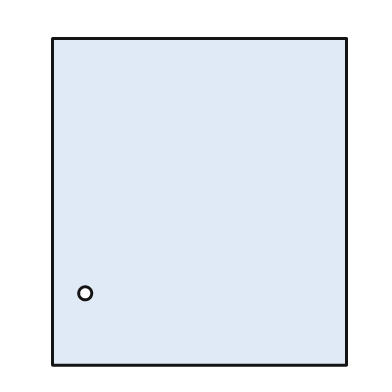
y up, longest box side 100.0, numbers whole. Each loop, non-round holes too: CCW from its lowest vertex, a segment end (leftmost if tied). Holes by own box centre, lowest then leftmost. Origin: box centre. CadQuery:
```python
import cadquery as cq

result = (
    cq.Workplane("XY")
    .moveTo(-45.0, -50.0)
    .lineTo(45.0, -50.0)
    .lineTo(45.0, 50.0)
    .lineTo(-45.0, 50.0)
    .close()
    .moveTo(-35.0, -28.0)
    .circle(2.0)
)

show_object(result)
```